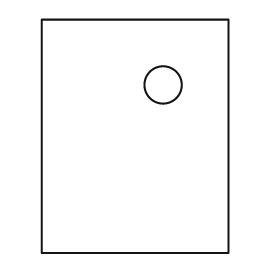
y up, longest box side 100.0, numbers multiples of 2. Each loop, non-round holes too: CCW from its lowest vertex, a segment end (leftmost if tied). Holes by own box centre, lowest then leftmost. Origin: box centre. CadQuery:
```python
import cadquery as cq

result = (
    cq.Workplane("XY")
    .moveTo(-40.0, -50.0)
    .lineTo(40.0, -50.0)
    .lineTo(40.0, 50.0)
    .lineTo(-40.0, 50.0)
    .close()
    .moveTo(12.0, 22.0)
    .circle(8.0)
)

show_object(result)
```